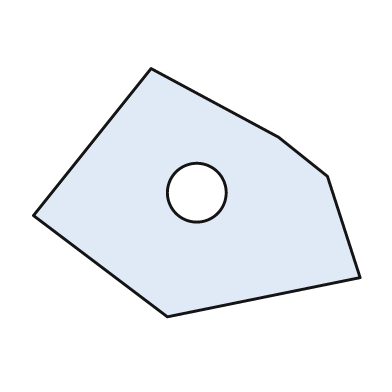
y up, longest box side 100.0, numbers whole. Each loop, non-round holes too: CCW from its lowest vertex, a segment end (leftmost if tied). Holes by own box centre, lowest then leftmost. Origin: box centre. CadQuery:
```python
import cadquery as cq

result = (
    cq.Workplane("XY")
    .moveTo(-9.0, -38.0)
    .lineTo(50.0, -26.0)
    .lineTo(40.0, 5.0)
    .lineTo(25.0, 17.0)
    .lineTo(-14.0, 38.0)
    .lineTo(-50.0, -7.0)
    .close()
    .moveTo(0.0, 0.0)
    .circle(9.0)
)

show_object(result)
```